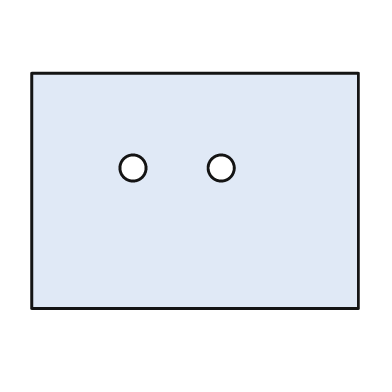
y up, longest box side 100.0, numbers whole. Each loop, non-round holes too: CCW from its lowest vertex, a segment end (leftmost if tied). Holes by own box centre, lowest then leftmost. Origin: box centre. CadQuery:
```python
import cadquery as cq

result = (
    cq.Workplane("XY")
    .moveTo(-50.0, -36.0)
    .lineTo(50.0, -36.0)
    .lineTo(50.0, 36.0)
    .lineTo(-50.0, 36.0)
    .close()
    .moveTo(-19.0, 7.0)
    .circle(4.0)
    .moveTo(8.0, 7.0)
    .circle(4.0)
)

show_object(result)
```